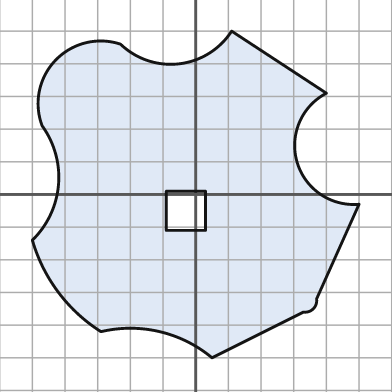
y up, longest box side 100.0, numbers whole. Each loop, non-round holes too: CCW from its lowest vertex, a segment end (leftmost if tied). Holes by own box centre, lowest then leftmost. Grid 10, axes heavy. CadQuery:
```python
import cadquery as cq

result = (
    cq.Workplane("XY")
    .moveTo(5.0, -50.0)
    .lineTo(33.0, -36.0)
    .threePointArc((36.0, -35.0), (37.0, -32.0))
    .lineTo(50.0, -3.0)
    .threePointArc((31.0, 10.0), (40.0, 31.0))
    .lineTo(11.0, 50.0)
    .threePointArc((-5.0, 40.0), (-23.0, 46.0))
    .threePointArc((-43.0, 41.0), (-47.0, 21.0))
    .threePointArc((-42.0, 3.0), (-50.0, -14.0))
    .threePointArc((-42.0, -30.0), (-29.0, -42.0))
    .threePointArc((-11.0, -42.0), (5.0, -50.0))
    .close()
    .moveTo(-9.0, -11.0)
    .lineTo(3.0, -11.0)
    .lineTo(3.0, 1.0)
    .lineTo(-9.0, 1.0)
    .close()
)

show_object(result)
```